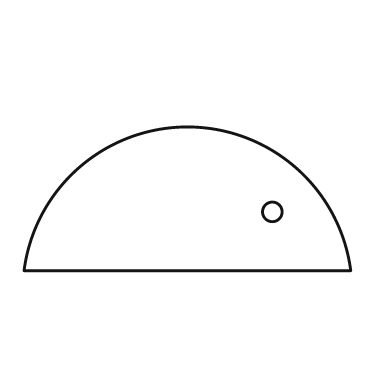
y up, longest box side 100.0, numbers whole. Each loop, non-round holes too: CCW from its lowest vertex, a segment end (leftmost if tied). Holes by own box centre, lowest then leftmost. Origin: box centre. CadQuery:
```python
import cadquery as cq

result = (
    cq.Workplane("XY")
    .moveTo(-50.0, -22.0)
    .lineTo(50.0, -22.0)
    .threePointArc((0.0, 22.0), (-50.0, -22.0))
    .close()
    .moveTo(26.0, -4.0)
    .circle(3.0)
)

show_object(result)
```